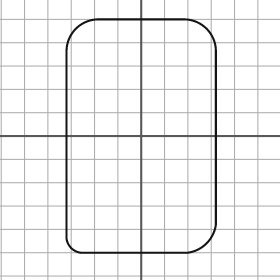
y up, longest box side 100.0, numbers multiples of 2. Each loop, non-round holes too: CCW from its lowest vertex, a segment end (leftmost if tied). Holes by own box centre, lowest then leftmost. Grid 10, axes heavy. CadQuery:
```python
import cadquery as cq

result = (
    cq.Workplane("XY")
    .moveTo(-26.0, -50.0)
    .lineTo(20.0, -50.0)
    .threePointArc((28.0, -46.0), (32.0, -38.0))
    .lineTo(32.0, 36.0)
    .threePointArc((28.0, 46.0), (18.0, 50.0))
    .lineTo(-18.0, 50.0)
    .threePointArc((-28.0, 46.0), (-32.0, 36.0))
    .lineTo(-32.0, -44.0)
    .threePointArc((-30.0, -48.0), (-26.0, -50.0))
    .close()
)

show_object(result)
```